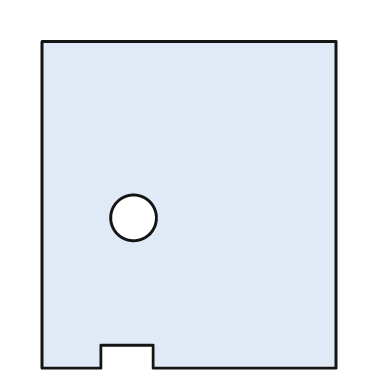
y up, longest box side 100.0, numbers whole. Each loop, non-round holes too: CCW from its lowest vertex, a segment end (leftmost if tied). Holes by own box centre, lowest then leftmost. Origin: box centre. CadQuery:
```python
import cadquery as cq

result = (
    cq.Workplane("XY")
    .moveTo(-45.0, -50.0)
    .lineTo(-27.0, -50.0)
    .lineTo(-27.0, -43.0)
    .lineTo(-11.0, -43.0)
    .lineTo(-11.0, -50.0)
    .lineTo(45.0, -50.0)
    .lineTo(45.0, 50.0)
    .lineTo(-45.0, 50.0)
    .close()
    .moveTo(-17.0, -4.0)
    .circle(7.0)
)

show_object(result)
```